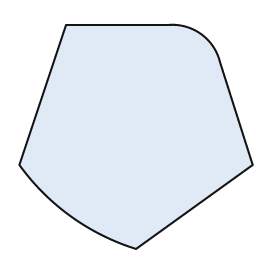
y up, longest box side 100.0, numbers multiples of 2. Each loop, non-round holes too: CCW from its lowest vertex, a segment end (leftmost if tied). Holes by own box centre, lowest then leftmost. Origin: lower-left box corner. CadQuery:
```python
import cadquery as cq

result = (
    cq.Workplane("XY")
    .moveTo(50.0, 0.0)
    .lineTo(100.0, 36.0)
    .lineTo(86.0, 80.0)
    .threePointArc((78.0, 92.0), (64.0, 96.0))
    .lineTo(20.0, 96.0)
    .lineTo(0.0, 36.0)
    .threePointArc((22.0, 14.0), (50.0, 0.0))
    .close()
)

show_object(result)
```